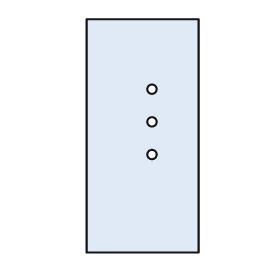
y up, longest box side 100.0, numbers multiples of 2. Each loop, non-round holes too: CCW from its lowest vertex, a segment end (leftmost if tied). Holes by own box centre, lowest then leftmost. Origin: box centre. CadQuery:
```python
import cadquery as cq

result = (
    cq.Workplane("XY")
    .moveTo(-24.0, -50.0)
    .lineTo(24.0, -50.0)
    .lineTo(24.0, 50.0)
    .lineTo(-24.0, 50.0)
    .close()
    .moveTo(4.0, -8.0)
    .circle(2.0)
    .moveTo(4.0, 6.0)
    .circle(2.0)
    .moveTo(4.0, 20.0)
    .circle(2.0)
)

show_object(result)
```